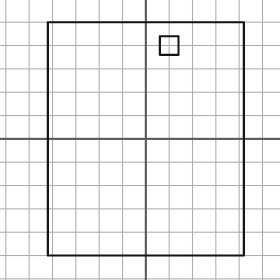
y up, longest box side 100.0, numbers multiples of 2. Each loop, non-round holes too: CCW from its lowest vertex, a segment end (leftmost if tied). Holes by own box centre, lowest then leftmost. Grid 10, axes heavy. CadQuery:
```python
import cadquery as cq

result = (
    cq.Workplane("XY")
    .moveTo(-42.0, -50.0)
    .lineTo(42.0, -50.0)
    .lineTo(42.0, 50.0)
    .lineTo(-42.0, 50.0)
    .close()
    .moveTo(6.0, 36.0)
    .lineTo(14.0, 36.0)
    .lineTo(14.0, 44.0)
    .lineTo(6.0, 44.0)
    .close()
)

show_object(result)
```